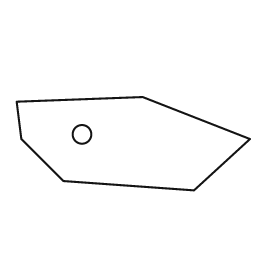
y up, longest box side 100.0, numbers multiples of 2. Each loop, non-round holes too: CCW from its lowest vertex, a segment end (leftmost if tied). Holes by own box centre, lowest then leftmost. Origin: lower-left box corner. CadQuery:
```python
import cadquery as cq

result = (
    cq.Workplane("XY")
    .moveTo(76.0, 0.0)
    .lineTo(100.0, 22.0)
    .lineTo(54.0, 40.0)
    .lineTo(0.0, 38.0)
    .lineTo(2.0, 22.0)
    .lineTo(20.0, 4.0)
    .close()
    .moveTo(28.0, 24.0)
    .circle(4.0)
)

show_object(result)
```